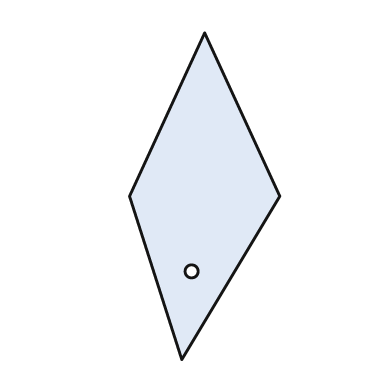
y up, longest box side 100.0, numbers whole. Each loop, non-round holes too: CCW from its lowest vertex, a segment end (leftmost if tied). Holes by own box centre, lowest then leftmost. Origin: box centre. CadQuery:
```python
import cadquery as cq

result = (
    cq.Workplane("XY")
    .moveTo(-7.0, -50.0)
    .lineTo(23.0, 0.0)
    .lineTo(0.0, 50.0)
    .lineTo(-23.0, 0.0)
    .close()
    .moveTo(-4.0, -23.0)
    .circle(2.0)
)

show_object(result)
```